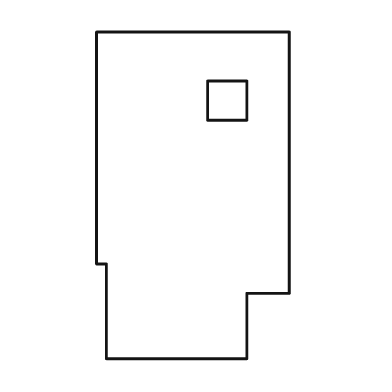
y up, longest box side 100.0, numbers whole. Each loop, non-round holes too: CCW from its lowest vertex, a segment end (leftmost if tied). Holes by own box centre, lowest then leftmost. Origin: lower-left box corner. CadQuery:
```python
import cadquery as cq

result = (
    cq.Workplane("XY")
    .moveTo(3.0, 0.0)
    .lineTo(46.0, 0.0)
    .lineTo(46.0, 20.0)
    .lineTo(59.0, 20.0)
    .lineTo(59.0, 100.0)
    .lineTo(0.0, 100.0)
    .lineTo(0.0, 29.0)
    .lineTo(3.0, 29.0)
    .close()
    .moveTo(34.0, 73.0)
    .lineTo(46.0, 73.0)
    .lineTo(46.0, 85.0)
    .lineTo(34.0, 85.0)
    .close()
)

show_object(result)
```